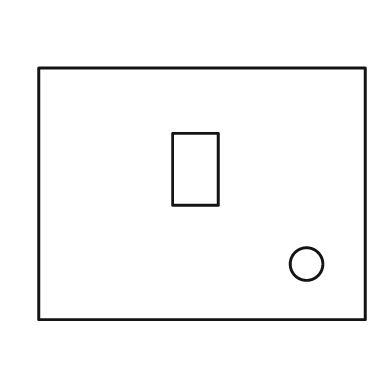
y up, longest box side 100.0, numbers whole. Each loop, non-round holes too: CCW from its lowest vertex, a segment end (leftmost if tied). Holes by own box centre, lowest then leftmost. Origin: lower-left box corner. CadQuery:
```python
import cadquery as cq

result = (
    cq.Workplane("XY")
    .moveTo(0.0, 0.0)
    .lineTo(100.0, 0.0)
    .lineTo(100.0, 77.0)
    .lineTo(0.0, 77.0)
    .close()
    .moveTo(82.0, 17.0)
    .circle(5.0)
    .moveTo(41.0, 35.0)
    .lineTo(55.0, 35.0)
    .lineTo(55.0, 57.0)
    .lineTo(41.0, 57.0)
    .close()
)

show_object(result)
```